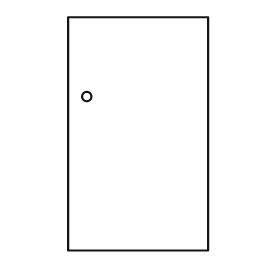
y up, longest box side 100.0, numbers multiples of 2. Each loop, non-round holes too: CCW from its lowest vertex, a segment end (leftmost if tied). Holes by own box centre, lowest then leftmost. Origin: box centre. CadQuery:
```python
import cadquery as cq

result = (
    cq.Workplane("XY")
    .moveTo(-30.0, -50.0)
    .lineTo(30.0, -50.0)
    .lineTo(30.0, 50.0)
    .lineTo(-30.0, 50.0)
    .close()
    .moveTo(-22.0, 16.0)
    .circle(2.0)
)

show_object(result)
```